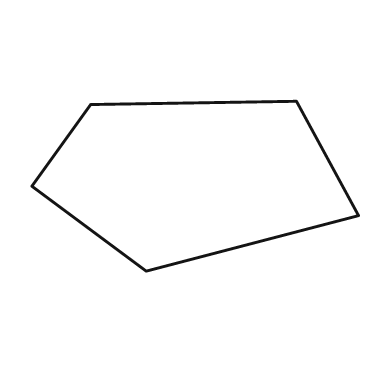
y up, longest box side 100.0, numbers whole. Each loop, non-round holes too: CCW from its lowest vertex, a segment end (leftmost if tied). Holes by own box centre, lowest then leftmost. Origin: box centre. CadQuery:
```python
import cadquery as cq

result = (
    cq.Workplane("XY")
    .moveTo(-15.0, -26.0)
    .lineTo(50.0, -9.0)
    .lineTo(31.0, 26.0)
    .lineTo(-32.0, 25.0)
    .lineTo(-50.0, 0.0)
    .close()
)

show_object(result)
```